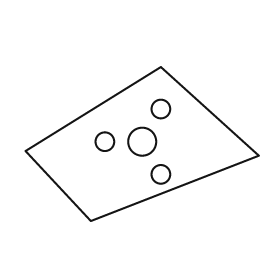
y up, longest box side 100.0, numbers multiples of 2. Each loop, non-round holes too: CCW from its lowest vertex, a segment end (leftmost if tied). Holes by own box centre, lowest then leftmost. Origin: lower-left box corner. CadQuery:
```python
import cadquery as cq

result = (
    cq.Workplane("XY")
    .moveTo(28.0, 0.0)
    .lineTo(100.0, 28.0)
    .lineTo(58.0, 66.0)
    .lineTo(0.0, 30.0)
    .close()
    .moveTo(58.0, 20.0)
    .circle(4.0)
    .moveTo(34.0, 34.0)
    .circle(4.0)
    .moveTo(50.0, 34.0)
    .circle(6.0)
    .moveTo(58.0, 48.0)
    .circle(4.0)
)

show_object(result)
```